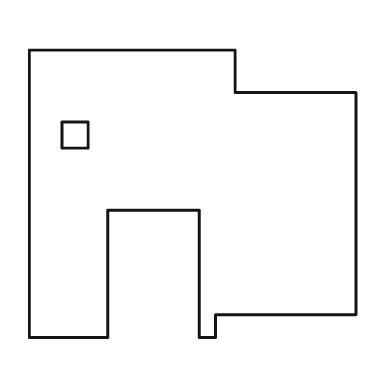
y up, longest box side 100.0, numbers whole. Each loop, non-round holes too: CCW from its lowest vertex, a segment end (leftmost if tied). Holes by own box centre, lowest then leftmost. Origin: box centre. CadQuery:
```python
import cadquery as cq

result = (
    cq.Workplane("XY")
    .moveTo(-50.0, -44.0)
    .lineTo(-26.0, -44.0)
    .lineTo(-26.0, -5.0)
    .lineTo(2.0, -5.0)
    .lineTo(2.0, -44.0)
    .lineTo(7.0, -44.0)
    .lineTo(7.0, -37.0)
    .lineTo(50.0, -37.0)
    .lineTo(50.0, 31.0)
    .lineTo(13.0, 31.0)
    .lineTo(13.0, 44.0)
    .lineTo(-50.0, 44.0)
    .close()
    .moveTo(-40.0, 14.0)
    .lineTo(-32.0, 14.0)
    .lineTo(-32.0, 22.0)
    .lineTo(-40.0, 22.0)
    .close()
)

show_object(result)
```